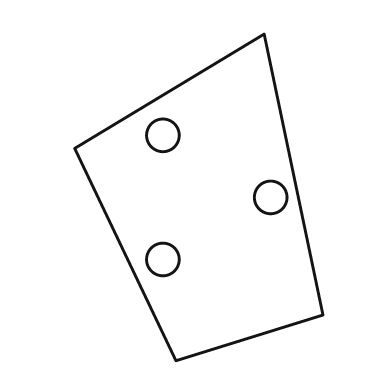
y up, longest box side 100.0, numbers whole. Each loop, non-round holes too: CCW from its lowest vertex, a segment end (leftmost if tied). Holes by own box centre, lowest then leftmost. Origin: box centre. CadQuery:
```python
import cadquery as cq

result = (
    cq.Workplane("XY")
    .moveTo(-7.0, -50.0)
    .lineTo(38.0, -36.0)
    .lineTo(20.0, 50.0)
    .lineTo(-38.0, 15.0)
    .close()
    .moveTo(-11.0, -19.0)
    .circle(5.0)
    .moveTo(22.0, 0.0)
    .circle(5.0)
    .moveTo(-11.0, 19.0)
    .circle(5.0)
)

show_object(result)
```